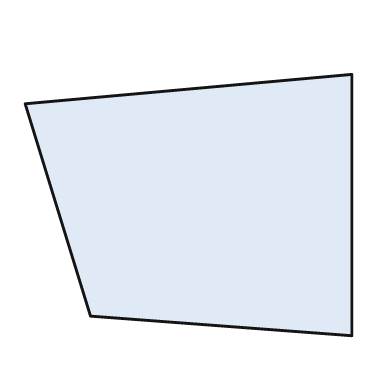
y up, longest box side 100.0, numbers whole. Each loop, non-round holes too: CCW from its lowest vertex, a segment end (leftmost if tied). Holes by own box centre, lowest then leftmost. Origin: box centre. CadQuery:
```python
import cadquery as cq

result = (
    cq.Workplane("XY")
    .moveTo(50.0, -40.0)
    .lineTo(50.0, 40.0)
    .lineTo(-50.0, 31.0)
    .lineTo(-30.0, -34.0)
    .close()
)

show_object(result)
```